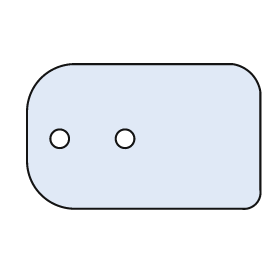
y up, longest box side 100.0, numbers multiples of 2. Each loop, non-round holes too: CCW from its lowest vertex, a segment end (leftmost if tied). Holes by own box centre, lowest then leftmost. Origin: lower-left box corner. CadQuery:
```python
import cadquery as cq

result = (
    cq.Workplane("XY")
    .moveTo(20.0, 0.0)
    .lineTo(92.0, 0.0)
    .threePointArc((98.0, 2.0), (100.0, 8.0))
    .lineTo(100.0, 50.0)
    .threePointArc((96.0, 58.0), (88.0, 62.0))
    .lineTo(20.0, 62.0)
    .threePointArc((6.0, 56.0), (0.0, 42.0))
    .lineTo(0.0, 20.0)
    .threePointArc((6.0, 6.0), (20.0, 0.0))
    .close()
    .moveTo(14.0, 30.0)
    .circle(4.0)
    .moveTo(42.0, 30.0)
    .circle(4.0)
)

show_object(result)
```